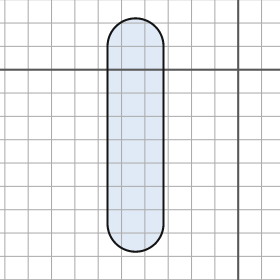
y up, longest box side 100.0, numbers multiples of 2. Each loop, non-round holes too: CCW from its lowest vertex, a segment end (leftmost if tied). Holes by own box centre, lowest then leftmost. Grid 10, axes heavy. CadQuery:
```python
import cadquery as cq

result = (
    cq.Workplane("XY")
    .moveTo(-56.0, -66.0)
    .threePointArc((-44.0, -78.0), (-32.0, -66.0))
    .lineTo(-32.0, 10.0)
    .threePointArc((-44.0, 22.0), (-56.0, 10.0))
    .close()
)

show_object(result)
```